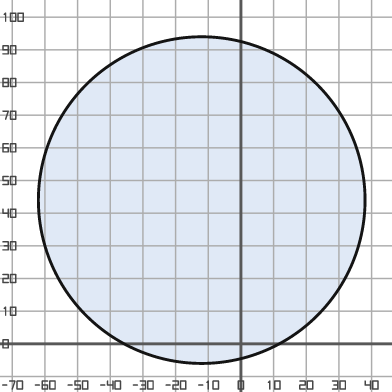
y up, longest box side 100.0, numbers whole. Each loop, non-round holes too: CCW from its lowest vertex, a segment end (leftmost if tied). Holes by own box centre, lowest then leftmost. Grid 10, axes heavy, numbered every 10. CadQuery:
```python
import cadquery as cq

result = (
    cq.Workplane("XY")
    .moveTo(-12.0, 44.0)
    .circle(50.0)
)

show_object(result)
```